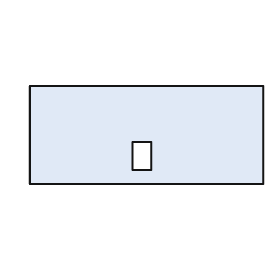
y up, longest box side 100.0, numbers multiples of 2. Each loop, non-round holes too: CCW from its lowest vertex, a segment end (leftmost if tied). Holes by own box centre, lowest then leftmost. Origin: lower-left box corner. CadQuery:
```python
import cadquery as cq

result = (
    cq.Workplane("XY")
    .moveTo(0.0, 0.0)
    .lineTo(100.0, 0.0)
    .lineTo(100.0, 42.0)
    .lineTo(0.0, 42.0)
    .close()
    .moveTo(44.0, 6.0)
    .lineTo(52.0, 6.0)
    .lineTo(52.0, 18.0)
    .lineTo(44.0, 18.0)
    .close()
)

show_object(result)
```